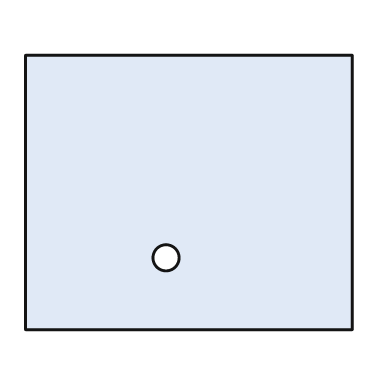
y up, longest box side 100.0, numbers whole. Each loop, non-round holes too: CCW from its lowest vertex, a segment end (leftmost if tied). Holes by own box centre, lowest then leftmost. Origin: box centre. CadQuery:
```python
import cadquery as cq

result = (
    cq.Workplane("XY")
    .moveTo(-50.0, -42.0)
    .lineTo(50.0, -42.0)
    .lineTo(50.0, 42.0)
    .lineTo(-50.0, 42.0)
    .close()
    .moveTo(-7.0, -20.0)
    .circle(4.0)
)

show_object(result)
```